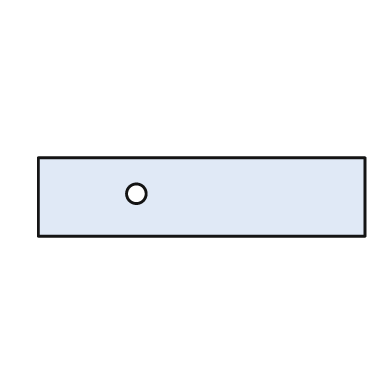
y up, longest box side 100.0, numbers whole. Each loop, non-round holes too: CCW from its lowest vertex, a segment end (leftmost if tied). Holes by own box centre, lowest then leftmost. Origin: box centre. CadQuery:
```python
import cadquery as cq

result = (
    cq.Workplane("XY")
    .moveTo(-50.0, -12.0)
    .lineTo(50.0, -12.0)
    .lineTo(50.0, 12.0)
    .lineTo(-50.0, 12.0)
    .close()
    .moveTo(-20.0, 1.0)
    .circle(3.0)
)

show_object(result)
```